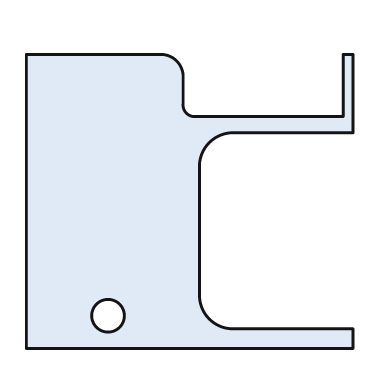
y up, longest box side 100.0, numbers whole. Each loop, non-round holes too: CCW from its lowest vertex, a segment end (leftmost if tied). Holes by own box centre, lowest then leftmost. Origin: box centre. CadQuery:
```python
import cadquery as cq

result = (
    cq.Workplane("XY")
    .moveTo(-50.0, -45.0)
    .lineTo(50.0, -45.0)
    .lineTo(50.0, -39.0)
    .lineTo(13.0, -39.0)
    .threePointArc((6.0, -36.0), (3.0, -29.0))
    .lineTo(3.0, 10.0)
    .threePointArc((6.0, 18.0), (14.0, 21.0))
    .lineTo(50.0, 21.0)
    .lineTo(50.0, 45.0)
    .lineTo(47.0, 45.0)
    .lineTo(47.0, 26.0)
    .lineTo(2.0, 26.0)
    .threePointArc((-1.0, 27.0), (-2.0, 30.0))
    .lineTo(-2.0, 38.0)
    .threePointArc((-4.0, 43.0), (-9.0, 45.0))
    .lineTo(-50.0, 45.0)
    .close()
    .moveTo(-25.0, -35.0)
    .circle(5.0)
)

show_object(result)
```